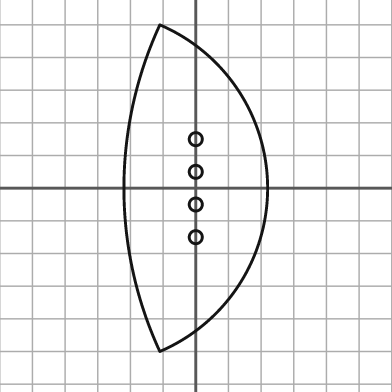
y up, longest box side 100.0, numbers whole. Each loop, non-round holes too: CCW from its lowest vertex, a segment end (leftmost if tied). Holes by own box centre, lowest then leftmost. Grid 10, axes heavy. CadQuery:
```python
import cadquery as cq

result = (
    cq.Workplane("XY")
    .moveTo(-11.0, -50.0)
    .threePointArc((22.0, 0.0), (-11.0, 50.0))
    .threePointArc((-22.0, 0.0), (-11.0, -50.0))
    .close()
    .moveTo(0.0, -15.0)
    .circle(2.0)
    .moveTo(0.0, -5.0)
    .circle(2.0)
    .moveTo(0.0, 5.0)
    .circle(2.0)
    .moveTo(0.0, 15.0)
    .circle(2.0)
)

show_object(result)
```